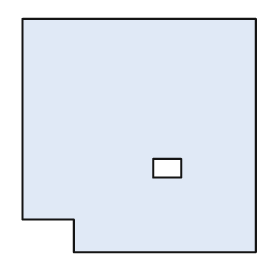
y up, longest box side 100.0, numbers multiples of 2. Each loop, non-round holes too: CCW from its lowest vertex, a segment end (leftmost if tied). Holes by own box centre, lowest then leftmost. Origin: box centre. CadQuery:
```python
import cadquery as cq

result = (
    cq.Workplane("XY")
    .moveTo(-28.0, -50.0)
    .lineTo(50.0, -50.0)
    .lineTo(50.0, 50.0)
    .lineTo(-50.0, 50.0)
    .lineTo(-50.0, -36.0)
    .lineTo(-28.0, -36.0)
    .close()
    .moveTo(6.0, -18.0)
    .lineTo(18.0, -18.0)
    .lineTo(18.0, -10.0)
    .lineTo(6.0, -10.0)
    .close()
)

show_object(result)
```